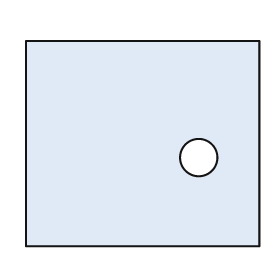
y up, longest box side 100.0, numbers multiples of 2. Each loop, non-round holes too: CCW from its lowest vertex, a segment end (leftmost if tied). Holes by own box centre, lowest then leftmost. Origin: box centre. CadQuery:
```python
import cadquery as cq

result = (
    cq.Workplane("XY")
    .moveTo(-50.0, -44.0)
    .lineTo(50.0, -44.0)
    .lineTo(50.0, 44.0)
    .lineTo(-50.0, 44.0)
    .close()
    .moveTo(24.0, -6.0)
    .circle(8.0)
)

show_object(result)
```